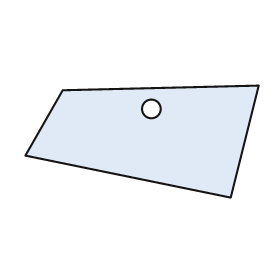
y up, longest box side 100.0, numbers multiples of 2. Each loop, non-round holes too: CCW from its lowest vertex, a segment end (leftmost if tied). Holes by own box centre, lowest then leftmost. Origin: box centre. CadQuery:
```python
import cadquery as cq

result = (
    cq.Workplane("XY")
    .moveTo(38.0, -24.0)
    .lineTo(50.0, 24.0)
    .lineTo(-34.0, 22.0)
    .lineTo(-50.0, -6.0)
    .close()
    .moveTo(4.0, 14.0)
    .circle(4.0)
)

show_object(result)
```